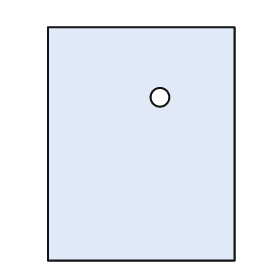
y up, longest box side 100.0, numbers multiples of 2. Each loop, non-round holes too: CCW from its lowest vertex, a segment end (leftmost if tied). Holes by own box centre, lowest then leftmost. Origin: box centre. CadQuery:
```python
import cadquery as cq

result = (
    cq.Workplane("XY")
    .moveTo(-40.0, -50.0)
    .lineTo(40.0, -50.0)
    .lineTo(40.0, 50.0)
    .lineTo(-40.0, 50.0)
    .close()
    .moveTo(8.0, 20.0)
    .circle(4.0)
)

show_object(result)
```